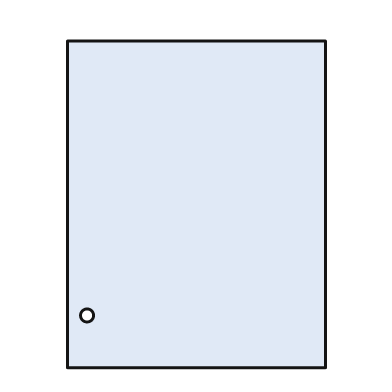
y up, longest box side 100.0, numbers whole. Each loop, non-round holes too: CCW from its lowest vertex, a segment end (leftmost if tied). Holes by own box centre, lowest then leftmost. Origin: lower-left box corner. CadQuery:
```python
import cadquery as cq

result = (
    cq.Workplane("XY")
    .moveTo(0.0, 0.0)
    .lineTo(79.0, 0.0)
    .lineTo(79.0, 100.0)
    .lineTo(0.0, 100.0)
    .close()
    .moveTo(6.0, 16.0)
    .circle(2.0)
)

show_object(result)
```